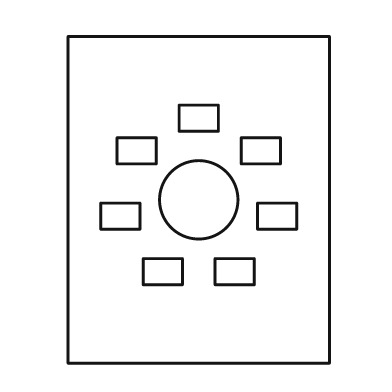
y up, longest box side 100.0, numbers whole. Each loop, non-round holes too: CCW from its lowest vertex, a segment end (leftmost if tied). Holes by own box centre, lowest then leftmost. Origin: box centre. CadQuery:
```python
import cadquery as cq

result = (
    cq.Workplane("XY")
    .moveTo(-40.0, -50.0)
    .lineTo(40.0, -50.0)
    .lineTo(40.0, 50.0)
    .lineTo(-40.0, 50.0)
    .close()
    .moveTo(-17.0, -26.0)
    .lineTo(-5.0, -26.0)
    .lineTo(-5.0, -18.0)
    .lineTo(-17.0, -18.0)
    .close()
    .moveTo(5.0, -26.0)
    .lineTo(17.0, -26.0)
    .lineTo(17.0, -18.0)
    .lineTo(5.0, -18.0)
    .close()
    .moveTo(-30.0, -9.0)
    .lineTo(-18.0, -9.0)
    .lineTo(-18.0, -1.0)
    .lineTo(-30.0, -1.0)
    .close()
    .moveTo(18.0, -9.0)
    .lineTo(30.0, -9.0)
    .lineTo(30.0, -1.0)
    .lineTo(18.0, -1.0)
    .close()
    .moveTo(0.0, 0.0)
    .circle(12.0)
    .moveTo(-25.0, 11.0)
    .lineTo(-13.0, 11.0)
    .lineTo(-13.0, 19.0)
    .lineTo(-25.0, 19.0)
    .close()
    .moveTo(13.0, 11.0)
    .lineTo(25.0, 11.0)
    .lineTo(25.0, 19.0)
    .lineTo(13.0, 19.0)
    .close()
    .moveTo(-6.0, 21.0)
    .lineTo(6.0, 21.0)
    .lineTo(6.0, 29.0)
    .lineTo(-6.0, 29.0)
    .close()
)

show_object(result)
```